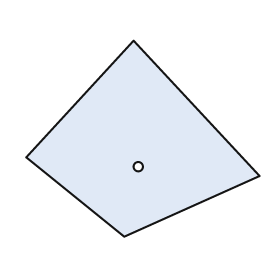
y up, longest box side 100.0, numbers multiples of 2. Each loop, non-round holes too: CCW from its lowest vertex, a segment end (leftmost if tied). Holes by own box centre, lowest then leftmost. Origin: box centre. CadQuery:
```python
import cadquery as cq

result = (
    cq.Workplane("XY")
    .moveTo(-8.0, -42.0)
    .lineTo(50.0, -16.0)
    .lineTo(-4.0, 42.0)
    .lineTo(-50.0, -8.0)
    .close()
    .moveTo(-2.0, -12.0)
    .circle(2.0)
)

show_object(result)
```